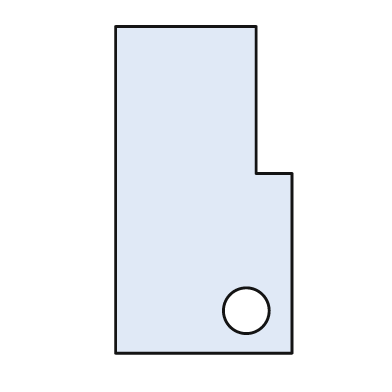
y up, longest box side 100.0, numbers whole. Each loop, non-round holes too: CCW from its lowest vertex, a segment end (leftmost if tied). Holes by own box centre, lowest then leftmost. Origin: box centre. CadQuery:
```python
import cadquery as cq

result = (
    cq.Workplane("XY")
    .moveTo(-27.0, -50.0)
    .lineTo(27.0, -50.0)
    .lineTo(27.0, 5.0)
    .lineTo(16.0, 5.0)
    .lineTo(16.0, 50.0)
    .lineTo(-27.0, 50.0)
    .close()
    .moveTo(13.0, -37.0)
    .circle(7.0)
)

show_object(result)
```